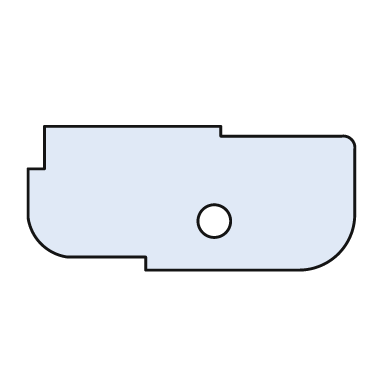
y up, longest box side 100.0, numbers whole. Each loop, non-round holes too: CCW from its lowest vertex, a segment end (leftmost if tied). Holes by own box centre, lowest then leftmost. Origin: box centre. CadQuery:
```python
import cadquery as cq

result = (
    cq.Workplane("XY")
    .moveTo(-14.0, -22.0)
    .lineTo(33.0, -22.0)
    .threePointArc((45.0, -17.0), (50.0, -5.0))
    .lineTo(50.0, 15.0)
    .threePointArc((49.0, 18.0), (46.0, 19.0))
    .lineTo(9.0, 19.0)
    .lineTo(9.0, 22.0)
    .lineTo(-45.0, 22.0)
    .lineTo(-45.0, 9.0)
    .lineTo(-50.0, 9.0)
    .lineTo(-50.0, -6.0)
    .threePointArc((-46.0, -14.0), (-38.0, -18.0))
    .lineTo(-14.0, -18.0)
    .close()
    .moveTo(7.0, -7.0)
    .circle(5.0)
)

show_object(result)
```